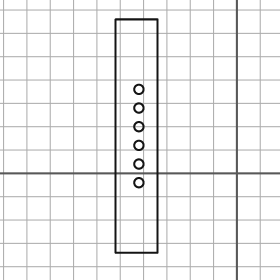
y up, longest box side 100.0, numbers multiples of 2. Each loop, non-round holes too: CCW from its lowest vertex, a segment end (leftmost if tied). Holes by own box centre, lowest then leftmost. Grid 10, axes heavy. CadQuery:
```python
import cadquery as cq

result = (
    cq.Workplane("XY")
    .moveTo(-52.0, -34.0)
    .lineTo(-34.0, -34.0)
    .lineTo(-34.0, 66.0)
    .lineTo(-52.0, 66.0)
    .close()
    .moveTo(-42.0, -4.0)
    .circle(2.0)
    .moveTo(-42.0, 4.0)
    .circle(2.0)
    .moveTo(-42.0, 12.0)
    .circle(2.0)
    .moveTo(-42.0, 20.0)
    .circle(2.0)
    .moveTo(-42.0, 28.0)
    .circle(2.0)
    .moveTo(-42.0, 36.0)
    .circle(2.0)
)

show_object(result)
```